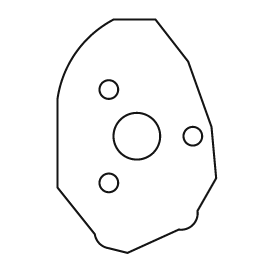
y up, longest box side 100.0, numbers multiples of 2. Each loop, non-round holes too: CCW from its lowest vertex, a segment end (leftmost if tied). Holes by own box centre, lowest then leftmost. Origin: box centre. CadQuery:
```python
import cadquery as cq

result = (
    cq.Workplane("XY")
    .moveTo(-4.0, -50.0)
    .lineTo(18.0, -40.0)
    .threePointArc((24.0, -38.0), (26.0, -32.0))
    .lineTo(34.0, -18.0)
    .lineTo(32.0, 4.0)
    .lineTo(22.0, 32.0)
    .lineTo(8.0, 50.0)
    .lineTo(-10.0, 50.0)
    .threePointArc((-26.0, 36.0), (-34.0, 16.0))
    .lineTo(-34.0, -22.0)
    .lineTo(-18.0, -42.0)
    .threePointArc((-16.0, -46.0), (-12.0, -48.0))
    .close()
    .moveTo(-12.0, -20.0)
    .circle(4.0)
    .moveTo(0.0, 0.0)
    .circle(10.0)
    .moveTo(24.0, 0.0)
    .circle(4.0)
    .moveTo(-12.0, 20.0)
    .circle(4.0)
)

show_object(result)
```